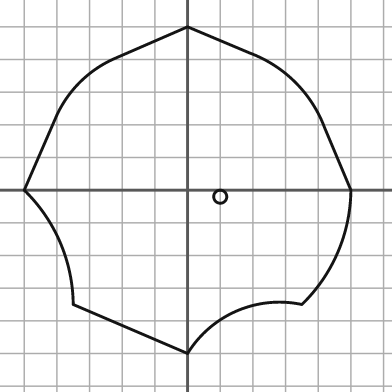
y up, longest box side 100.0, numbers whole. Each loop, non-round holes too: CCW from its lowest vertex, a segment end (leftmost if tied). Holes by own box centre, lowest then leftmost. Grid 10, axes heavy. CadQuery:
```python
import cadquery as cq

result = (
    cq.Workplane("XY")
    .moveTo(0.0, -50.0)
    .threePointArc((15.0, -37.0), (35.0, -35.0))
    .threePointArc((46.0, -19.0), (50.0, 0.0))
    .lineTo(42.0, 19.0)
    .threePointArc((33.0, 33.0), (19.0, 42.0))
    .lineTo(0.0, 50.0)
    .lineTo(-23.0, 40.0)
    .threePointArc((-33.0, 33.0), (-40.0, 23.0))
    .lineTo(-50.0, 0.0)
    .threePointArc((-39.0, -16.0), (-35.0, -35.0))
    .close()
    .moveTo(10.0, -2.0)
    .circle(2.0)
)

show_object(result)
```